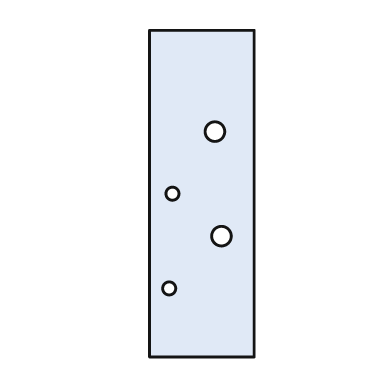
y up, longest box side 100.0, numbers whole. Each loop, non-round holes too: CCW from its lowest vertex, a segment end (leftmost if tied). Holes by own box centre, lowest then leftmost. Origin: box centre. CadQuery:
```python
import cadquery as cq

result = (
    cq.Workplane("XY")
    .moveTo(-16.0, -50.0)
    .lineTo(16.0, -50.0)
    .lineTo(16.0, 50.0)
    .lineTo(-16.0, 50.0)
    .close()
    .moveTo(-10.0, -29.0)
    .circle(2.0)
    .moveTo(6.0, -13.0)
    .circle(3.0)
    .moveTo(-9.0, 0.0)
    .circle(2.0)
    .moveTo(4.0, 19.0)
    .circle(3.0)
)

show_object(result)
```